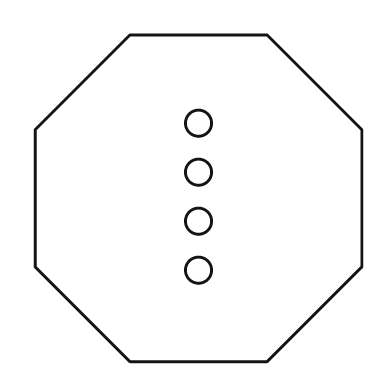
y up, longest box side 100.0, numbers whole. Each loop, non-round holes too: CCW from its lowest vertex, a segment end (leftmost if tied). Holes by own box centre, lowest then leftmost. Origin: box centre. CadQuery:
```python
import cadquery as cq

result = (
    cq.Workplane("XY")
    .moveTo(-21.0, -50.0)
    .lineTo(21.0, -50.0)
    .lineTo(50.0, -21.0)
    .lineTo(50.0, 21.0)
    .lineTo(21.0, 50.0)
    .lineTo(-21.0, 50.0)
    .lineTo(-50.0, 21.0)
    .lineTo(-50.0, -21.0)
    .close()
    .moveTo(0.0, -22.0)
    .circle(4.0)
    .moveTo(0.0, -7.0)
    .circle(4.0)
    .moveTo(0.0, 8.0)
    .circle(4.0)
    .moveTo(0.0, 23.0)
    .circle(4.0)
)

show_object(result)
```